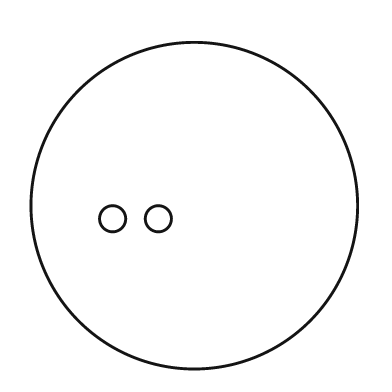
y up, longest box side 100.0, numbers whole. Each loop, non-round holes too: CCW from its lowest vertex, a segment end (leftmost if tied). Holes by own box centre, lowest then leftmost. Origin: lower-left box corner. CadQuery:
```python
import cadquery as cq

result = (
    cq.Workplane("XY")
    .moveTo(50.0, 50.0)
    .circle(50.0)
    .moveTo(25.0, 46.0)
    .circle(4.0)
    .moveTo(39.0, 46.0)
    .circle(4.0)
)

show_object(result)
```